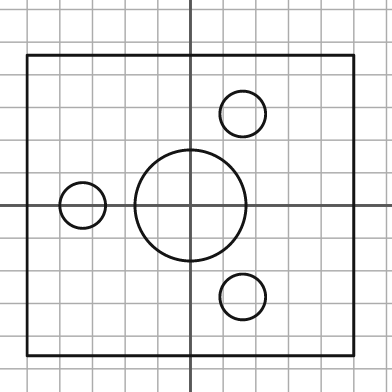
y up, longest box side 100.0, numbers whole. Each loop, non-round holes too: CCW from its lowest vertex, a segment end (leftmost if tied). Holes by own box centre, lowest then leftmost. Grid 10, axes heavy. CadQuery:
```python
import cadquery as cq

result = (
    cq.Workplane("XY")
    .moveTo(-50.0, -46.0)
    .lineTo(50.0, -46.0)
    .lineTo(50.0, 46.0)
    .lineTo(-50.0, 46.0)
    .close()
    .moveTo(16.0, -28.0)
    .circle(7.0)
    .moveTo(-33.0, 0.0)
    .circle(7.0)
    .moveTo(0.0, 0.0)
    .circle(17.0)
    .moveTo(16.0, 28.0)
    .circle(7.0)
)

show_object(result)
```